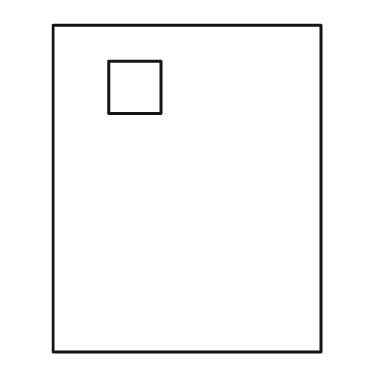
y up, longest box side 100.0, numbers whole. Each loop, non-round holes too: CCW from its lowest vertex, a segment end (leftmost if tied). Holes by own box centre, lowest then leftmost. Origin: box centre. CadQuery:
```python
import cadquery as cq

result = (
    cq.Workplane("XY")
    .moveTo(-41.0, -50.0)
    .lineTo(41.0, -50.0)
    .lineTo(41.0, 50.0)
    .lineTo(-41.0, 50.0)
    .close()
    .moveTo(-24.0, 23.0)
    .lineTo(-8.0, 23.0)
    .lineTo(-8.0, 39.0)
    .lineTo(-24.0, 39.0)
    .close()
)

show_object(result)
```